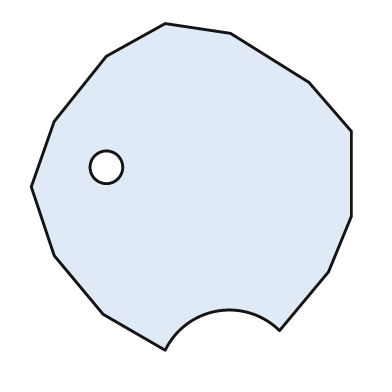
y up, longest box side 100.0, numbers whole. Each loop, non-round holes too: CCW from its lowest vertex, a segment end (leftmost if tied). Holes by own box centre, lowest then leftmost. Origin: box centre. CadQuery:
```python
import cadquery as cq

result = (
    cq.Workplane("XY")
    .moveTo(-8.0, -50.0)
    .threePointArc((8.0, -38.0), (27.0, -44.0))
    .lineTo(42.0, -26.0)
    .lineTo(49.0, -9.0)
    .lineTo(49.0, 17.0)
    .lineTo(36.0, 32.0)
    .lineTo(12.0, 47.0)
    .lineTo(-8.0, 50.0)
    .lineTo(-26.0, 40.0)
    .lineTo(-42.0, 20.0)
    .lineTo(-49.0, 0.0)
    .lineTo(-42.0, -21.0)
    .lineTo(-27.0, -39.0)
    .close()
    .moveTo(-26.0, 6.0)
    .circle(5.0)
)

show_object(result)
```